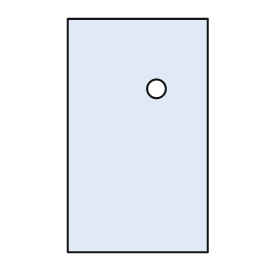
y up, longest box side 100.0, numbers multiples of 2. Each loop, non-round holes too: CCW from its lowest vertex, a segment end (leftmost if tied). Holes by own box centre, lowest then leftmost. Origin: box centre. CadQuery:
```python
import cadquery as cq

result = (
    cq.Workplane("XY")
    .moveTo(-30.0, -50.0)
    .lineTo(30.0, -50.0)
    .lineTo(30.0, 50.0)
    .lineTo(-30.0, 50.0)
    .close()
    .moveTo(8.0, 20.0)
    .circle(4.0)
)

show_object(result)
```